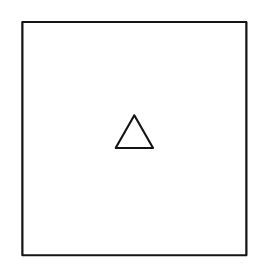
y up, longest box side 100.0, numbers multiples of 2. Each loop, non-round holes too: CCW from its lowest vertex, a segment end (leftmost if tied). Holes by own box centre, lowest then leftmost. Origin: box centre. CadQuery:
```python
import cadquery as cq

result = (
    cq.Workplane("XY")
    .moveTo(-48.0, -50.0)
    .lineTo(48.0, -50.0)
    .lineTo(48.0, 50.0)
    .lineTo(-48.0, 50.0)
    .close()
    .moveTo(-8.0, -4.0)
    .lineTo(8.0, -4.0)
    .lineTo(0.0, 10.0)
    .close()
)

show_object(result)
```